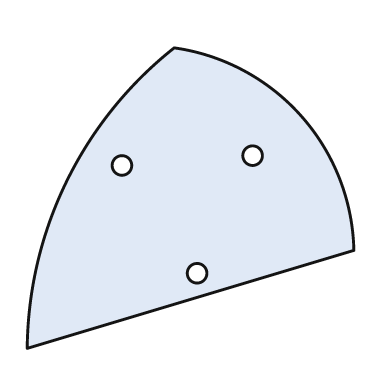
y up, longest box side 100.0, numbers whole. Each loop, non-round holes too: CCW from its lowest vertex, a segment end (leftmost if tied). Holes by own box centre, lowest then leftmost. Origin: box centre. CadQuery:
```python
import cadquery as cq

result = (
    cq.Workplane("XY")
    .moveTo(-50.0, -46.0)
    .lineTo(50.0, -16.0)
    .threePointArc((34.0, 25.0), (-5.0, 46.0))
    .threePointArc((-38.0, 5.0), (-50.0, -46.0))
    .close()
    .moveTo(2.0, -23.0)
    .circle(3.0)
    .moveTo(-21.0, 10.0)
    .circle(3.0)
    .moveTo(19.0, 13.0)
    .circle(3.0)
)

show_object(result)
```